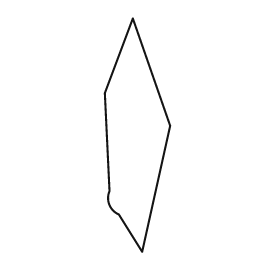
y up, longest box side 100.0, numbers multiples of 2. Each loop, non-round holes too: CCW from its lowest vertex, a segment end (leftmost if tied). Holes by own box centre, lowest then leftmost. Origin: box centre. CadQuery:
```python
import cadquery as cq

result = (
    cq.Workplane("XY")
    .moveTo(2.0, -50.0)
    .lineTo(14.0, 4.0)
    .lineTo(-2.0, 50.0)
    .lineTo(-14.0, 18.0)
    .lineTo(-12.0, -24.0)
    .threePointArc((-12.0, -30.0), (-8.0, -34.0))
    .close()
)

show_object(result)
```